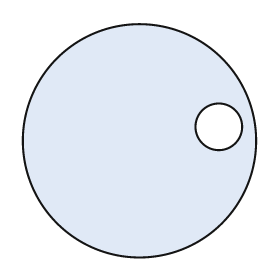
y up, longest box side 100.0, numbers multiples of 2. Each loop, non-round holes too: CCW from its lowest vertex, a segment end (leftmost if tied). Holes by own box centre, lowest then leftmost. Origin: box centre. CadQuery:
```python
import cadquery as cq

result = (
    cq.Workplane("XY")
    .moveTo(0.0, 0.0)
    .circle(50.0)
    .moveTo(34.0, 6.0)
    .circle(10.0)
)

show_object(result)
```